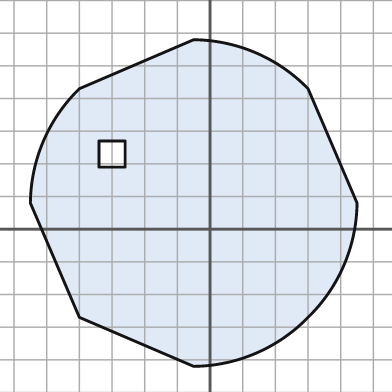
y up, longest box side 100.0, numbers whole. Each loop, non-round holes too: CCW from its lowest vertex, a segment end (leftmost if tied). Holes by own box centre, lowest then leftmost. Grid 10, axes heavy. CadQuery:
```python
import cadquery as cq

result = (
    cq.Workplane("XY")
    .moveTo(-5.0, -42.0)
    .threePointArc((14.0, -38.0), (30.0, -27.0))
    .threePointArc((41.0, -11.0), (45.0, 8.0))
    .lineTo(30.0, 43.0)
    .threePointArc((14.0, 54.0), (-5.0, 58.0))
    .lineTo(-40.0, 43.0)
    .threePointArc((-51.0, 27.0), (-55.0, 8.0))
    .lineTo(-40.0, -27.0)
    .close()
    .moveTo(-34.0, 19.0)
    .lineTo(-26.0, 19.0)
    .lineTo(-26.0, 27.0)
    .lineTo(-34.0, 27.0)
    .close()
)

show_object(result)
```